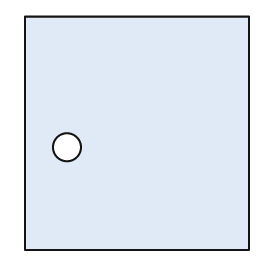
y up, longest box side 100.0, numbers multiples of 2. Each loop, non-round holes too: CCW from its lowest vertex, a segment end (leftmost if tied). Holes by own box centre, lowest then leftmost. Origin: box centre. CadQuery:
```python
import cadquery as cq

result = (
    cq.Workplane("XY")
    .moveTo(-48.0, -50.0)
    .lineTo(48.0, -50.0)
    .lineTo(48.0, 50.0)
    .lineTo(-48.0, 50.0)
    .close()
    .moveTo(-30.0, -6.0)
    .circle(6.0)
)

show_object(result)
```